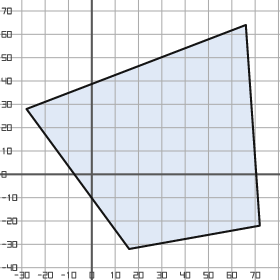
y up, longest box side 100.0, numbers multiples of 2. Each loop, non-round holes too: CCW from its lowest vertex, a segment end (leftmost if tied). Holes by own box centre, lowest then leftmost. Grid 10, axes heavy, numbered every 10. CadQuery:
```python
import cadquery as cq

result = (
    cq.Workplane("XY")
    .moveTo(16.0, -32.0)
    .lineTo(72.0, -22.0)
    .lineTo(66.0, 64.0)
    .lineTo(-28.0, 28.0)
    .close()
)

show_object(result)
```